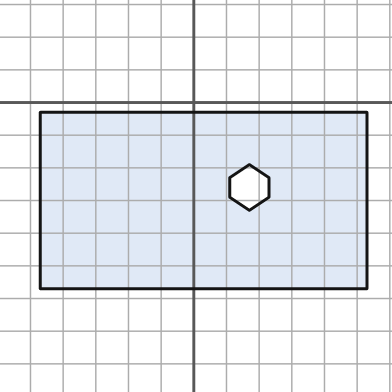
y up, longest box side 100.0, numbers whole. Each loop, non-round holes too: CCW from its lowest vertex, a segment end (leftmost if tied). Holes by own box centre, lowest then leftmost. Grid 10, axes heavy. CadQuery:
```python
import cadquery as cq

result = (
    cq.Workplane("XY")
    .moveTo(-47.0, -57.0)
    .lineTo(53.0, -57.0)
    .lineTo(53.0, -3.0)
    .lineTo(-47.0, -3.0)
    .close()
    .moveTo(17.0, -33.0)
    .lineTo(23.0, -29.0)
    .lineTo(23.0, -23.0)
    .lineTo(17.0, -19.0)
    .lineTo(11.0, -23.0)
    .lineTo(11.0, -29.0)
    .close()
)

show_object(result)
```